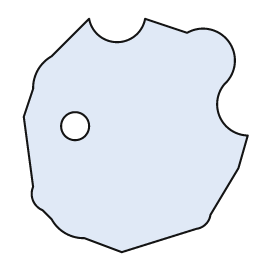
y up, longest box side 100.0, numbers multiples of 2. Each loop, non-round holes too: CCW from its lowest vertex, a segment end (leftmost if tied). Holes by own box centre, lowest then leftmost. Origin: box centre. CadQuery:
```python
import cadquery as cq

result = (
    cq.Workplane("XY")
    .moveTo(-6.0, -50.0)
    .lineTo(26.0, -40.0)
    .threePointArc((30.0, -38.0), (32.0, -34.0))
    .lineTo(44.0, -14.0)
    .lineTo(48.0, 0.0)
    .threePointArc((36.0, 8.0), (38.0, 22.0))
    .threePointArc((40.0, 40.0), (22.0, 44.0))
    .lineTo(4.0, 50.0)
    .threePointArc((-8.0, 40.0), (-20.0, 50.0))
    .lineTo(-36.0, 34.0)
    .threePointArc((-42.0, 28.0), (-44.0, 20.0))
    .lineTo(-48.0, 8.0)
    .lineTo(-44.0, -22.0)
    .threePointArc((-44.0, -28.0), (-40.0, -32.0))
    .lineTo(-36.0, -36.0)
    .threePointArc((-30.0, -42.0), (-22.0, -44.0))
    .close()
    .moveTo(-26.0, 4.0)
    .circle(6.0)
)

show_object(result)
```